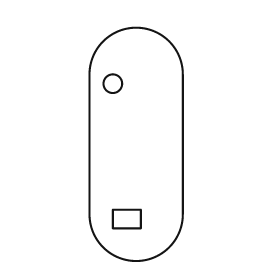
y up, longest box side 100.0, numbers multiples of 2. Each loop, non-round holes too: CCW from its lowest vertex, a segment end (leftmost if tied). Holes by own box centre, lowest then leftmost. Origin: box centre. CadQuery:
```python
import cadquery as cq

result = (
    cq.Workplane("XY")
    .moveTo(-20.0, -30.0)
    .threePointArc((0.0, -50.0), (20.0, -30.0))
    .lineTo(20.0, 30.0)
    .threePointArc((0.0, 50.0), (-20.0, 30.0))
    .close()
    .moveTo(-10.0, -36.0)
    .lineTo(2.0, -36.0)
    .lineTo(2.0, -28.0)
    .lineTo(-10.0, -28.0)
    .close()
    .moveTo(-10.0, 26.0)
    .circle(4.0)
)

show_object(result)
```